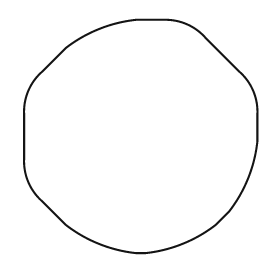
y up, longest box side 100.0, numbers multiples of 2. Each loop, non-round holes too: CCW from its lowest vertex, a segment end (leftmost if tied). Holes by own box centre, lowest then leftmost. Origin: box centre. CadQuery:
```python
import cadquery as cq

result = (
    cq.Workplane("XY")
    .moveTo(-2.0, -50.0)
    .lineTo(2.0, -50.0)
    .threePointArc((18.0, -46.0), (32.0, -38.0))
    .lineTo(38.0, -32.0)
    .threePointArc((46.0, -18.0), (50.0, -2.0))
    .lineTo(50.0, 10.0)
    .threePointArc((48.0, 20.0), (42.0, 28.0))
    .lineTo(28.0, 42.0)
    .threePointArc((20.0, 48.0), (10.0, 50.0))
    .lineTo(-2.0, 50.0)
    .threePointArc((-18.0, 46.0), (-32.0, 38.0))
    .lineTo(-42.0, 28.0)
    .threePointArc((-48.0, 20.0), (-50.0, 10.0))
    .lineTo(-50.0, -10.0)
    .threePointArc((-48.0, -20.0), (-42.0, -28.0))
    .lineTo(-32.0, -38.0)
    .threePointArc((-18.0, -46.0), (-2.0, -50.0))
    .close()
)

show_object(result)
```